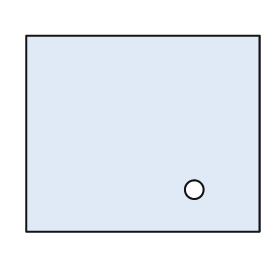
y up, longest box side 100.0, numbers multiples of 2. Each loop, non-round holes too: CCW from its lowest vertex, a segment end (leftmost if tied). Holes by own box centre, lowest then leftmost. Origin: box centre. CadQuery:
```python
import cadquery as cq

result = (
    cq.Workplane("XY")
    .moveTo(-50.0, -42.0)
    .lineTo(50.0, -42.0)
    .lineTo(50.0, 42.0)
    .lineTo(-50.0, 42.0)
    .close()
    .moveTo(22.0, -24.0)
    .circle(4.0)
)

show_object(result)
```